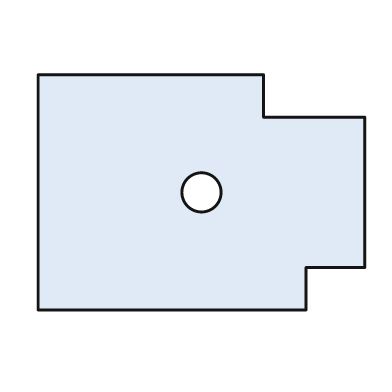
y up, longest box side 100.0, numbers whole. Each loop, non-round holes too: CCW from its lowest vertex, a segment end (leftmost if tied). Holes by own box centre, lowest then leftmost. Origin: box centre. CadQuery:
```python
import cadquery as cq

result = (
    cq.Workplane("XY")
    .moveTo(-50.0, -36.0)
    .lineTo(32.0, -36.0)
    .lineTo(32.0, -23.0)
    .lineTo(50.0, -23.0)
    .lineTo(50.0, 23.0)
    .lineTo(19.0, 23.0)
    .lineTo(19.0, 36.0)
    .lineTo(-50.0, 36.0)
    .close()
    .moveTo(0.0, 0.0)
    .circle(6.0)
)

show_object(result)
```